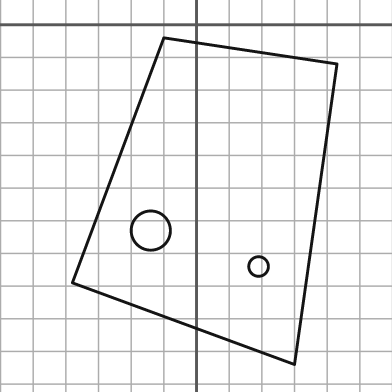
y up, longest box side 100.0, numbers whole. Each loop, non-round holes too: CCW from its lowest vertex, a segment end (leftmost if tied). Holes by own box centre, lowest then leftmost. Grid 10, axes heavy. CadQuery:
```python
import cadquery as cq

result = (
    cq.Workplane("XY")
    .moveTo(30.0, -104.0)
    .lineTo(43.0, -12.0)
    .lineTo(-10.0, -4.0)
    .lineTo(-38.0, -79.0)
    .close()
    .moveTo(19.0, -74.0)
    .circle(3.0)
    .moveTo(-14.0, -63.0)
    .circle(6.0)
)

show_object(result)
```